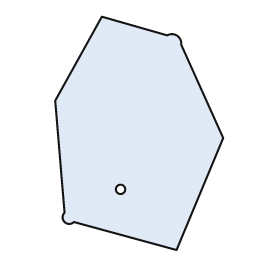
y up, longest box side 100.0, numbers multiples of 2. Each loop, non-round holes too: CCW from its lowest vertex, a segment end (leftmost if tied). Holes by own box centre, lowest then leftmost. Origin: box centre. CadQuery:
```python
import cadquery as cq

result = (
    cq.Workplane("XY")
    .moveTo(16.0, -50.0)
    .lineTo(36.0, -2.0)
    .lineTo(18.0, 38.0)
    .threePointArc((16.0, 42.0), (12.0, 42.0))
    .lineTo(-16.0, 50.0)
    .lineTo(-36.0, 14.0)
    .lineTo(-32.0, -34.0)
    .threePointArc((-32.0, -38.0), (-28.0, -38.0))
    .close()
    .moveTo(-8.0, -24.0)
    .circle(2.0)
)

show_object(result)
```